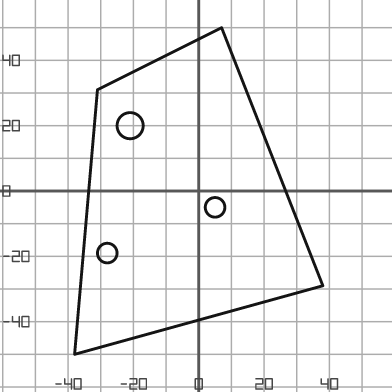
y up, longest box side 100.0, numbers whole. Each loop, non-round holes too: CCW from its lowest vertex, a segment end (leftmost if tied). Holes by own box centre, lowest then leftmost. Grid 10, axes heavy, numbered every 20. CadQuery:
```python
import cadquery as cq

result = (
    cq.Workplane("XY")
    .moveTo(-38.0, -50.0)
    .lineTo(38.0, -29.0)
    .lineTo(7.0, 50.0)
    .lineTo(-31.0, 31.0)
    .close()
    .moveTo(-28.0, -19.0)
    .circle(3.0)
    .moveTo(5.0, -5.0)
    .circle(3.0)
    .moveTo(-21.0, 20.0)
    .circle(4.0)
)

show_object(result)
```